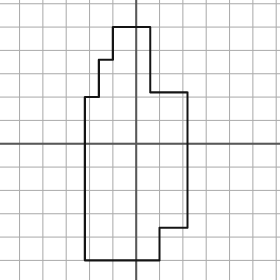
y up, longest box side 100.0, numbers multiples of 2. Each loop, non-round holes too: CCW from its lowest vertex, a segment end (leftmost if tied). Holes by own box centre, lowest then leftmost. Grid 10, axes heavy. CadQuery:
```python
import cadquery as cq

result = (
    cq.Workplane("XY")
    .moveTo(-22.0, -50.0)
    .lineTo(10.0, -50.0)
    .lineTo(10.0, -36.0)
    .lineTo(22.0, -36.0)
    .lineTo(22.0, 22.0)
    .lineTo(6.0, 22.0)
    .lineTo(6.0, 50.0)
    .lineTo(-10.0, 50.0)
    .lineTo(-10.0, 36.0)
    .lineTo(-16.0, 36.0)
    .lineTo(-16.0, 20.0)
    .lineTo(-22.0, 20.0)
    .close()
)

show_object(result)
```